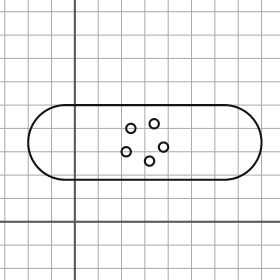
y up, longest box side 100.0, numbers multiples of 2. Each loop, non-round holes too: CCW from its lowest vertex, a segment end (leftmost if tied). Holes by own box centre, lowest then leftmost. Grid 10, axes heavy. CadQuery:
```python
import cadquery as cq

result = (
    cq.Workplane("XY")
    .moveTo(-4.0, 18.0)
    .lineTo(64.0, 18.0)
    .threePointArc((80.0, 34.0), (64.0, 50.0))
    .lineTo(-4.0, 50.0)
    .threePointArc((-20.0, 34.0), (-4.0, 18.0))
    .close()
    .moveTo(32.0, 26.0)
    .circle(2.0)
    .moveTo(22.0, 30.0)
    .circle(2.0)
    .moveTo(38.0, 32.0)
    .circle(2.0)
    .moveTo(24.0, 40.0)
    .circle(2.0)
    .moveTo(34.0, 42.0)
    .circle(2.0)
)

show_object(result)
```